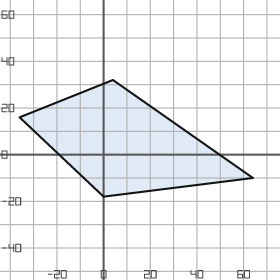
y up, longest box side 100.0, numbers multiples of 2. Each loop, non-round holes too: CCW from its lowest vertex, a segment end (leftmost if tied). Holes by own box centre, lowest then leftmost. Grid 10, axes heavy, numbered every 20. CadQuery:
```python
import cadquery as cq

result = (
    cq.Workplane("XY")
    .moveTo(0.0, -18.0)
    .lineTo(64.0, -10.0)
    .lineTo(4.0, 32.0)
    .lineTo(-36.0, 16.0)
    .close()
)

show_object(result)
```